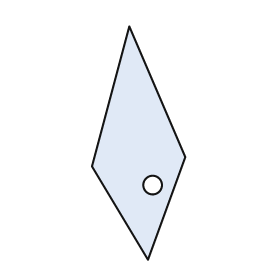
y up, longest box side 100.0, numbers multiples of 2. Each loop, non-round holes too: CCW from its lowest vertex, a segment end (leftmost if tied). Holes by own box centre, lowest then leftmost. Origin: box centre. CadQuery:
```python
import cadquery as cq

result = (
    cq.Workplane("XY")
    .moveTo(4.0, -50.0)
    .lineTo(20.0, -6.0)
    .lineTo(-4.0, 50.0)
    .lineTo(-20.0, -10.0)
    .close()
    .moveTo(6.0, -18.0)
    .circle(4.0)
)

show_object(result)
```